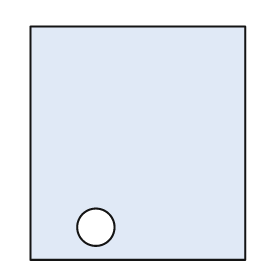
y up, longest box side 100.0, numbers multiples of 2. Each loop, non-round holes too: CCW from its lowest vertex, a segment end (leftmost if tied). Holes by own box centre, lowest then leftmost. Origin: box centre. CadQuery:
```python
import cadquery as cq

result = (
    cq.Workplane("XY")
    .moveTo(-46.0, -50.0)
    .lineTo(46.0, -50.0)
    .lineTo(46.0, 50.0)
    .lineTo(-46.0, 50.0)
    .close()
    .moveTo(-18.0, -36.0)
    .circle(8.0)
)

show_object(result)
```